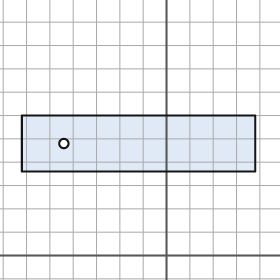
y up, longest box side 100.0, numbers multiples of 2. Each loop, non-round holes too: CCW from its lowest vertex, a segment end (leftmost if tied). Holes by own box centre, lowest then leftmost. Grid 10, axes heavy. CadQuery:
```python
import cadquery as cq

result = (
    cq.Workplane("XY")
    .moveTo(-62.0, 36.0)
    .lineTo(38.0, 36.0)
    .lineTo(38.0, 60.0)
    .lineTo(-62.0, 60.0)
    .close()
    .moveTo(-44.0, 48.0)
    .circle(2.0)
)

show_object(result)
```